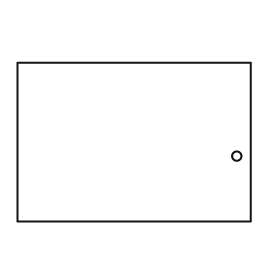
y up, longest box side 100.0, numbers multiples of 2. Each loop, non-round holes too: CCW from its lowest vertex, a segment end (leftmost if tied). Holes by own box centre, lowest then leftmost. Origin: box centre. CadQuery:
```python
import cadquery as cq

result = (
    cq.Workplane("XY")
    .moveTo(-50.0, -34.0)
    .lineTo(50.0, -34.0)
    .lineTo(50.0, 34.0)
    .lineTo(-50.0, 34.0)
    .close()
    .moveTo(44.0, -6.0)
    .circle(2.0)
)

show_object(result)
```